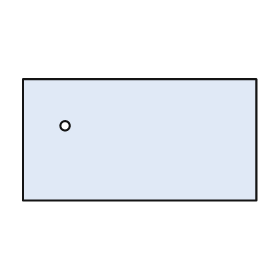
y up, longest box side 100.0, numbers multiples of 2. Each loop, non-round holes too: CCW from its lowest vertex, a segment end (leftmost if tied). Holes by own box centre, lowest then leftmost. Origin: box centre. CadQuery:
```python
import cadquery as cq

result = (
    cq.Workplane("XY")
    .moveTo(-50.0, -26.0)
    .lineTo(50.0, -26.0)
    .lineTo(50.0, 26.0)
    .lineTo(-50.0, 26.0)
    .close()
    .moveTo(-32.0, 6.0)
    .circle(2.0)
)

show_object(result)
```